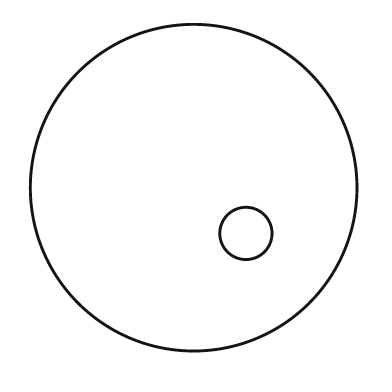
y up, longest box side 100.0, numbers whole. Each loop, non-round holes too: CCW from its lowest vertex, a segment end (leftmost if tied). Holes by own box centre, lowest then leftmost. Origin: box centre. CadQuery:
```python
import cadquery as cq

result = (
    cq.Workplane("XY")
    .moveTo(0.0, 0.0)
    .circle(50.0)
    .moveTo(16.0, -14.0)
    .circle(8.0)
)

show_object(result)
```